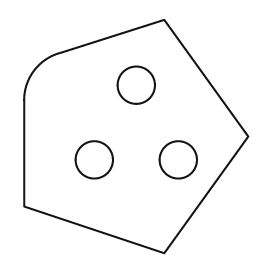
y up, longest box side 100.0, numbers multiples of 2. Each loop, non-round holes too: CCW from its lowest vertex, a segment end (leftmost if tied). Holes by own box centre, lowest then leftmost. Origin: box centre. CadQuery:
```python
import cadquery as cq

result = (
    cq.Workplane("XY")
    .moveTo(12.0, -50.0)
    .lineTo(48.0, 0.0)
    .lineTo(12.0, 50.0)
    .lineTo(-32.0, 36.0)
    .threePointArc((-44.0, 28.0), (-48.0, 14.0))
    .lineTo(-48.0, -30.0)
    .close()
    .moveTo(-18.0, -10.0)
    .circle(8.0)
    .moveTo(18.0, -10.0)
    .circle(8.0)
    .moveTo(0.0, 22.0)
    .circle(8.0)
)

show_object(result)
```